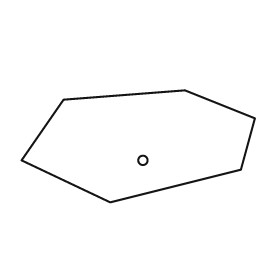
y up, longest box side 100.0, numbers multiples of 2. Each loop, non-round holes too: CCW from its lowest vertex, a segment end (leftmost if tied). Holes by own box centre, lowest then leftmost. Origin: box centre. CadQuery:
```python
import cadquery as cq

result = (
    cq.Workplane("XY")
    .moveTo(-12.0, -24.0)
    .lineTo(44.0, -10.0)
    .lineTo(50.0, 12.0)
    .lineTo(20.0, 24.0)
    .lineTo(-32.0, 20.0)
    .lineTo(-50.0, -6.0)
    .close()
    .moveTo(2.0, -6.0)
    .circle(2.0)
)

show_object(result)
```